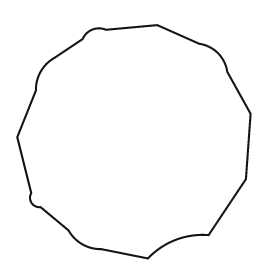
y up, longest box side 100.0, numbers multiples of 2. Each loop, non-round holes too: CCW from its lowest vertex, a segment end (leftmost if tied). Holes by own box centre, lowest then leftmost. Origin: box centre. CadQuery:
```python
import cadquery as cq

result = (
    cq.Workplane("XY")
    .moveTo(6.0, -50.0)
    .threePointArc((18.0, -42.0), (32.0, -40.0))
    .lineTo(48.0, -16.0)
    .lineTo(50.0, 12.0)
    .lineTo(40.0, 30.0)
    .threePointArc((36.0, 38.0), (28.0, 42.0))
    .lineTo(10.0, 50.0)
    .lineTo(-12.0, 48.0)
    .threePointArc((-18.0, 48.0), (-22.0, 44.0))
    .lineTo(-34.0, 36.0)
    .threePointArc((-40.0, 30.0), (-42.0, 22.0))
    .lineTo(-50.0, 2.0)
    .lineTo(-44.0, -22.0)
    .threePointArc((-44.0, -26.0), (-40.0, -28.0))
    .lineTo(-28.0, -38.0)
    .threePointArc((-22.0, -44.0), (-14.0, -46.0))
    .close()
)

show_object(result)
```